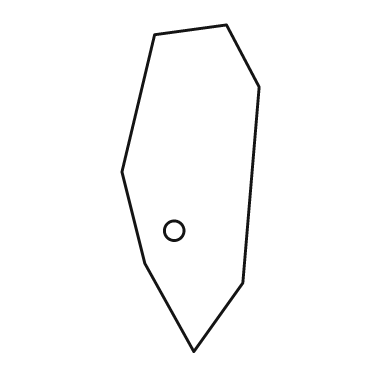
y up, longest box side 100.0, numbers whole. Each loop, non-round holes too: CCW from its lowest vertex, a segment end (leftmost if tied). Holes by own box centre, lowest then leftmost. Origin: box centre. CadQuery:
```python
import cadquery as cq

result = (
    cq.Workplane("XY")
    .moveTo(1.0, -50.0)
    .lineTo(16.0, -29.0)
    .lineTo(21.0, 31.0)
    .lineTo(11.0, 50.0)
    .lineTo(-11.0, 47.0)
    .lineTo(-21.0, 5.0)
    .lineTo(-14.0, -23.0)
    .close()
    .moveTo(-5.0, -13.0)
    .circle(3.0)
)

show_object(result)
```